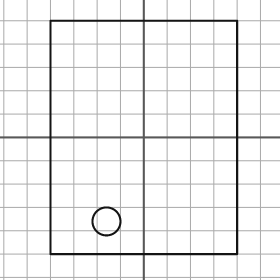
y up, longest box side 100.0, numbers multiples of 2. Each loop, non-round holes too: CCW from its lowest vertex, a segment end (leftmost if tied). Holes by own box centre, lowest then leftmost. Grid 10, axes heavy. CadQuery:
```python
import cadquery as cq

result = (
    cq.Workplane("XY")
    .moveTo(-40.0, -50.0)
    .lineTo(40.0, -50.0)
    .lineTo(40.0, 50.0)
    .lineTo(-40.0, 50.0)
    .close()
    .moveTo(-16.0, -36.0)
    .circle(6.0)
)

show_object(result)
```